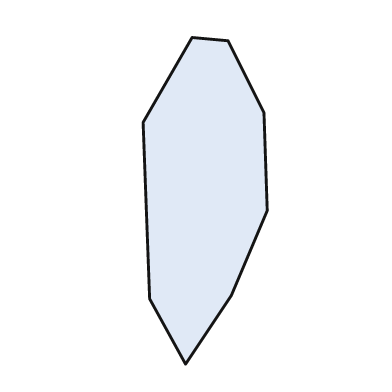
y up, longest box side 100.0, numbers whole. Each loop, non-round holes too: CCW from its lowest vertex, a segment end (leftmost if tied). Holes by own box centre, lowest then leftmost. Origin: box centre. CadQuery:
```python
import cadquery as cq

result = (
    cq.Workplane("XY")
    .moveTo(-6.0, -50.0)
    .lineTo(8.0, -29.0)
    .lineTo(19.0, -3.0)
    .lineTo(18.0, 27.0)
    .lineTo(7.0, 49.0)
    .lineTo(-4.0, 50.0)
    .lineTo(-19.0, 24.0)
    .lineTo(-17.0, -30.0)
    .close()
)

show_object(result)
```